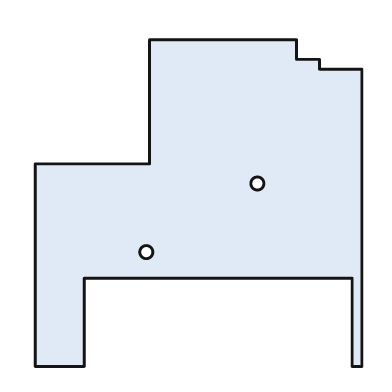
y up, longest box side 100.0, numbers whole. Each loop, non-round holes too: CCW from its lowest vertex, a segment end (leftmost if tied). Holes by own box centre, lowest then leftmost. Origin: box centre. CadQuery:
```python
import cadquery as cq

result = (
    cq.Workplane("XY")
    .moveTo(-50.0, -50.0)
    .lineTo(-35.0, -50.0)
    .lineTo(-35.0, -23.0)
    .lineTo(47.0, -23.0)
    .lineTo(47.0, -50.0)
    .lineTo(50.0, -50.0)
    .lineTo(50.0, 41.0)
    .lineTo(37.0, 41.0)
    .lineTo(37.0, 44.0)
    .lineTo(30.0, 44.0)
    .lineTo(30.0, 50.0)
    .lineTo(-15.0, 50.0)
    .lineTo(-15.0, 12.0)
    .lineTo(-50.0, 12.0)
    .close()
    .moveTo(-16.0, -15.0)
    .circle(2.0)
    .moveTo(18.0, 6.0)
    .circle(2.0)
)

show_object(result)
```